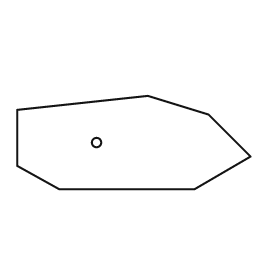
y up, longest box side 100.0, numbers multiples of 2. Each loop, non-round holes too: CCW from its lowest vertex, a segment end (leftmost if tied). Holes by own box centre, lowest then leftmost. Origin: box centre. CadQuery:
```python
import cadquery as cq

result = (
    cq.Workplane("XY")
    .moveTo(-32.0, -20.0)
    .lineTo(26.0, -20.0)
    .lineTo(50.0, -6.0)
    .lineTo(32.0, 12.0)
    .lineTo(6.0, 20.0)
    .lineTo(-50.0, 14.0)
    .lineTo(-50.0, -10.0)
    .close()
    .moveTo(-16.0, 0.0)
    .circle(2.0)
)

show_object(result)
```